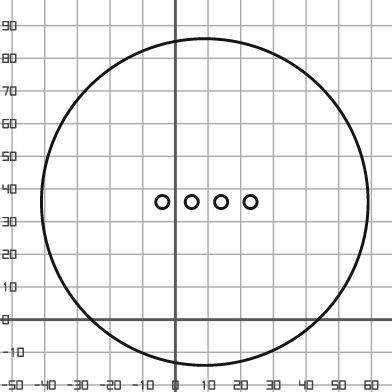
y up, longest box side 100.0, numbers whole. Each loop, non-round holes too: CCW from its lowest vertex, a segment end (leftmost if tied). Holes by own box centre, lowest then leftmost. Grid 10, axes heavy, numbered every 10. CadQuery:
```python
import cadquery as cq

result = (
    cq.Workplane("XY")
    .moveTo(9.0, 36.0)
    .circle(50.0)
    .moveTo(-4.0, 36.0)
    .circle(2.0)
    .moveTo(5.0, 36.0)
    .circle(2.0)
    .moveTo(14.0, 36.0)
    .circle(2.0)
    .moveTo(23.0, 36.0)
    .circle(2.0)
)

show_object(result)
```